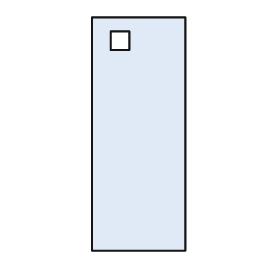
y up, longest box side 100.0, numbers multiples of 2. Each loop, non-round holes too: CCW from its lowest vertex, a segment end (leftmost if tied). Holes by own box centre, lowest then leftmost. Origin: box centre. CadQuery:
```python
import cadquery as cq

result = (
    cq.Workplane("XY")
    .moveTo(-20.0, -50.0)
    .lineTo(20.0, -50.0)
    .lineTo(20.0, 50.0)
    .lineTo(-20.0, 50.0)
    .close()
    .moveTo(-12.0, 36.0)
    .lineTo(-4.0, 36.0)
    .lineTo(-4.0, 44.0)
    .lineTo(-12.0, 44.0)
    .close()
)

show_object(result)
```